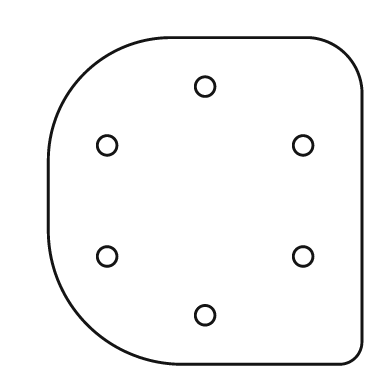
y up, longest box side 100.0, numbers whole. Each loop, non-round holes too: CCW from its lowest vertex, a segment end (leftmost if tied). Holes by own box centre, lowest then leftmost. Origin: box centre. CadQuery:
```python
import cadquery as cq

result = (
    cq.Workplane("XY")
    .moveTo(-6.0, -50.0)
    .lineTo(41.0, -50.0)
    .threePointArc((46.0, -48.0), (48.0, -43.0))
    .lineTo(48.0, 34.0)
    .threePointArc((43.0, 45.0), (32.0, 50.0))
    .lineTo(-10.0, 50.0)
    .threePointArc((-37.0, 39.0), (-48.0, 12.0))
    .lineTo(-48.0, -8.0)
    .threePointArc((-36.0, -38.0), (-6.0, -50.0))
    .close()
    .moveTo(0.0, -35.0)
    .circle(3.0)
    .moveTo(-30.0, -17.0)
    .circle(3.0)
    .moveTo(30.0, -17.0)
    .circle(3.0)
    .moveTo(-30.0, 17.0)
    .circle(3.0)
    .moveTo(30.0, 17.0)
    .circle(3.0)
    .moveTo(0.0, 35.0)
    .circle(3.0)
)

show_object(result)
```